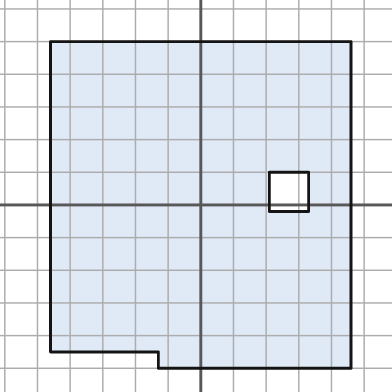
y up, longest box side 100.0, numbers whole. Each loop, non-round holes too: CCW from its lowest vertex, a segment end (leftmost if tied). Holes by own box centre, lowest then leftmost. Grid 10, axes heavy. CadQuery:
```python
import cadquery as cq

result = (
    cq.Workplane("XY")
    .moveTo(-13.0, -50.0)
    .lineTo(46.0, -50.0)
    .lineTo(46.0, 50.0)
    .lineTo(-46.0, 50.0)
    .lineTo(-46.0, -45.0)
    .lineTo(-13.0, -45.0)
    .close()
    .moveTo(21.0, -2.0)
    .lineTo(33.0, -2.0)
    .lineTo(33.0, 10.0)
    .lineTo(21.0, 10.0)
    .close()
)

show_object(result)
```